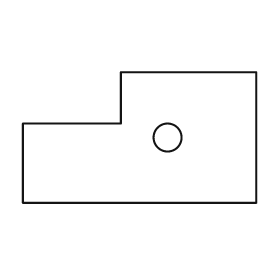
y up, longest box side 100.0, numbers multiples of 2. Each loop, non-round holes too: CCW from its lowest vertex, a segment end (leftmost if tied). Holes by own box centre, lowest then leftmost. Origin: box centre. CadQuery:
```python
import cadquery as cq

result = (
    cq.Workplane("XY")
    .moveTo(-50.0, -28.0)
    .lineTo(50.0, -28.0)
    .lineTo(50.0, 28.0)
    .lineTo(-8.0, 28.0)
    .lineTo(-8.0, 6.0)
    .lineTo(-50.0, 6.0)
    .close()
    .moveTo(12.0, 0.0)
    .circle(6.0)
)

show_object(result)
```